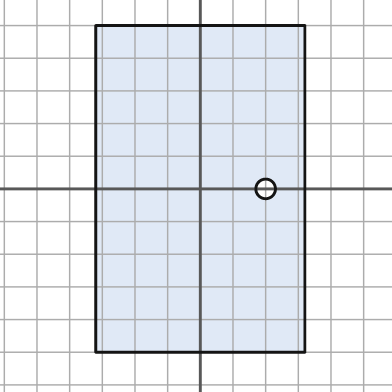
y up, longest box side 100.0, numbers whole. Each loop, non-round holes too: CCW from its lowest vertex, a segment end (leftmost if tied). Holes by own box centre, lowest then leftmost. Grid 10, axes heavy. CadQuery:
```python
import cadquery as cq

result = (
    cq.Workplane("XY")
    .moveTo(-32.0, -50.0)
    .lineTo(32.0, -50.0)
    .lineTo(32.0, 50.0)
    .lineTo(-32.0, 50.0)
    .close()
    .moveTo(20.0, 0.0)
    .circle(3.0)
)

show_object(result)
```